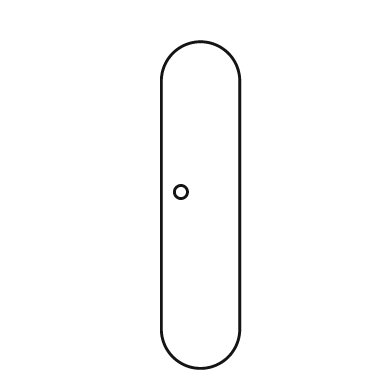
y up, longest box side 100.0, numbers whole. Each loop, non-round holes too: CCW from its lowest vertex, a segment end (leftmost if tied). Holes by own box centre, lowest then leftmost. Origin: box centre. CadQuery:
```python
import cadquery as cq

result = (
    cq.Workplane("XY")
    .moveTo(-12.0, -38.0)
    .threePointArc((0.0, -50.0), (12.0, -38.0))
    .lineTo(12.0, 38.0)
    .threePointArc((0.0, 50.0), (-12.0, 38.0))
    .close()
    .moveTo(-6.0, 4.0)
    .circle(2.0)
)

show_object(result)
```